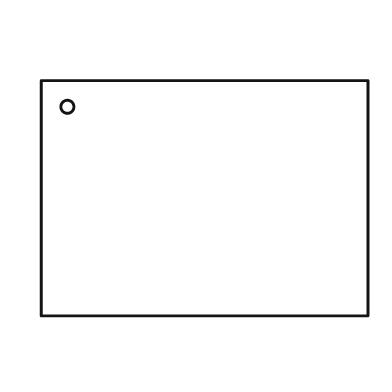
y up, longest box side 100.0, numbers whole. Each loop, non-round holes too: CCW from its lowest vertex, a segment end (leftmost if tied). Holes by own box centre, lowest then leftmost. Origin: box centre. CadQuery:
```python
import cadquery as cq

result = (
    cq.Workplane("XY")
    .moveTo(-50.0, -36.0)
    .lineTo(50.0, -36.0)
    .lineTo(50.0, 36.0)
    .lineTo(-50.0, 36.0)
    .close()
    .moveTo(-42.0, 28.0)
    .circle(2.0)
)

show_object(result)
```